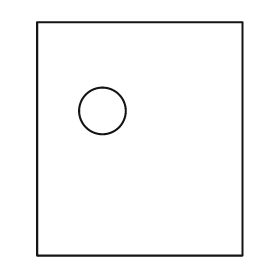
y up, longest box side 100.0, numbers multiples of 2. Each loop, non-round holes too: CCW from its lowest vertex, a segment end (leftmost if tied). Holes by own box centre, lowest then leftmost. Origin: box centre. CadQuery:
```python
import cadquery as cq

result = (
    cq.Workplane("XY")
    .moveTo(-44.0, -50.0)
    .lineTo(44.0, -50.0)
    .lineTo(44.0, 50.0)
    .lineTo(-44.0, 50.0)
    .close()
    .moveTo(-16.0, 12.0)
    .circle(10.0)
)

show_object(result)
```